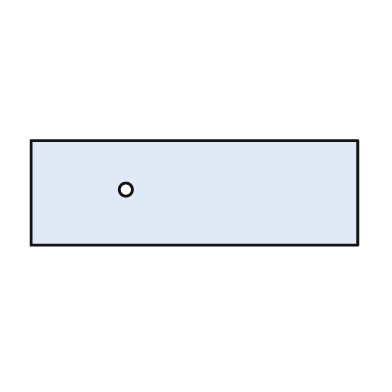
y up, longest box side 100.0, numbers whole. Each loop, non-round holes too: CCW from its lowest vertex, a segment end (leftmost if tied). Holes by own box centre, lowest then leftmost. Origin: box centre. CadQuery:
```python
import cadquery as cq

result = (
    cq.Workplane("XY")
    .moveTo(-50.0, -16.0)
    .lineTo(50.0, -16.0)
    .lineTo(50.0, 16.0)
    .lineTo(-50.0, 16.0)
    .close()
    .moveTo(-21.0, 1.0)
    .circle(2.0)
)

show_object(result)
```